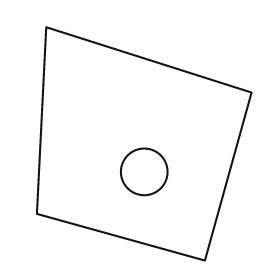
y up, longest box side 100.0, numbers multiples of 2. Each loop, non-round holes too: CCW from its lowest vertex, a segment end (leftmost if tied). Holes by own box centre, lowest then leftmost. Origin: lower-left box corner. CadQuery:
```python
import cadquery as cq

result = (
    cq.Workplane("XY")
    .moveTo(72.0, 0.0)
    .lineTo(92.0, 72.0)
    .lineTo(4.0, 100.0)
    .lineTo(0.0, 20.0)
    .close()
    .moveTo(46.0, 38.0)
    .circle(10.0)
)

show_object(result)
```